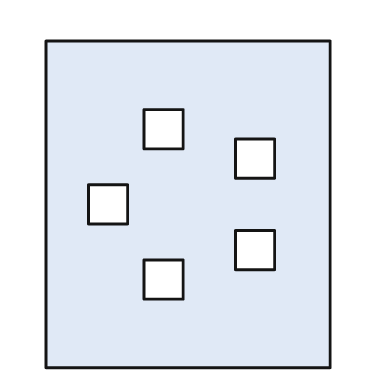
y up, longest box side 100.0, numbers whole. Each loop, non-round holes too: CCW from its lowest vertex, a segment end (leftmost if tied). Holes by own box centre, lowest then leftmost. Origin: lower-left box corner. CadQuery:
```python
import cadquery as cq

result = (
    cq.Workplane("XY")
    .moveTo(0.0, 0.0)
    .lineTo(87.0, 0.0)
    .lineTo(87.0, 100.0)
    .lineTo(0.0, 100.0)
    .close()
    .moveTo(30.0, 21.0)
    .lineTo(42.0, 21.0)
    .lineTo(42.0, 33.0)
    .lineTo(30.0, 33.0)
    .close()
    .moveTo(58.0, 30.0)
    .lineTo(70.0, 30.0)
    .lineTo(70.0, 42.0)
    .lineTo(58.0, 42.0)
    .close()
    .moveTo(13.0, 44.0)
    .lineTo(25.0, 44.0)
    .lineTo(25.0, 56.0)
    .lineTo(13.0, 56.0)
    .close()
    .moveTo(58.0, 58.0)
    .lineTo(70.0, 58.0)
    .lineTo(70.0, 70.0)
    .lineTo(58.0, 70.0)
    .close()
    .moveTo(30.0, 67.0)
    .lineTo(42.0, 67.0)
    .lineTo(42.0, 79.0)
    .lineTo(30.0, 79.0)
    .close()
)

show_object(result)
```